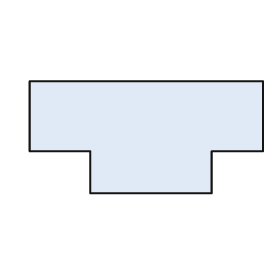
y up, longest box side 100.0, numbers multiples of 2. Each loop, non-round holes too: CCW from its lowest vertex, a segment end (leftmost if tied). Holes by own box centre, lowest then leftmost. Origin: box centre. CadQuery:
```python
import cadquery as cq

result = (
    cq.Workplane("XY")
    .moveTo(-24.0, -24.0)
    .lineTo(28.0, -24.0)
    .lineTo(28.0, -6.0)
    .lineTo(50.0, -6.0)
    .lineTo(50.0, 24.0)
    .lineTo(-50.0, 24.0)
    .lineTo(-50.0, -6.0)
    .lineTo(-24.0, -6.0)
    .close()
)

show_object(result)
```